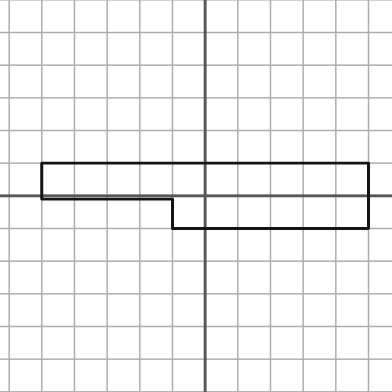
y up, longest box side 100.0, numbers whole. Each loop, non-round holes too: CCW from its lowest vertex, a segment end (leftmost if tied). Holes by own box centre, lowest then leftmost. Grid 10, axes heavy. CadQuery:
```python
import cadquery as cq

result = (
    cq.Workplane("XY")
    .moveTo(-10.0, -10.0)
    .lineTo(50.0, -10.0)
    .lineTo(50.0, 10.0)
    .lineTo(-50.0, 10.0)
    .lineTo(-50.0, -1.0)
    .lineTo(-10.0, -1.0)
    .close()
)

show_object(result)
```